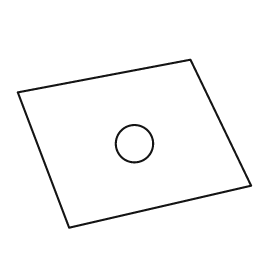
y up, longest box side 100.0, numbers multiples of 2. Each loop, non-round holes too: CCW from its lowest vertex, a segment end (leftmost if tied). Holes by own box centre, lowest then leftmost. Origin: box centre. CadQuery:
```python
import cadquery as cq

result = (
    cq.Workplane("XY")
    .moveTo(-28.0, -36.0)
    .lineTo(50.0, -18.0)
    .lineTo(24.0, 36.0)
    .lineTo(-50.0, 22.0)
    .close()
    .moveTo(0.0, 0.0)
    .circle(8.0)
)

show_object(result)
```